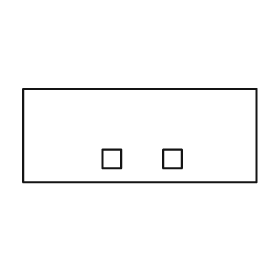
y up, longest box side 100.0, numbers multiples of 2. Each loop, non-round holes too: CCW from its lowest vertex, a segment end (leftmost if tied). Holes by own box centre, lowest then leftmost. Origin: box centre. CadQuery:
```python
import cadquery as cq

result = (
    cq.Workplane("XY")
    .moveTo(-50.0, -20.0)
    .lineTo(50.0, -20.0)
    .lineTo(50.0, 20.0)
    .lineTo(-50.0, 20.0)
    .close()
    .moveTo(-16.0, -14.0)
    .lineTo(-8.0, -14.0)
    .lineTo(-8.0, -6.0)
    .lineTo(-16.0, -6.0)
    .close()
    .moveTo(10.0, -14.0)
    .lineTo(18.0, -14.0)
    .lineTo(18.0, -6.0)
    .lineTo(10.0, -6.0)
    .close()
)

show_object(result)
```